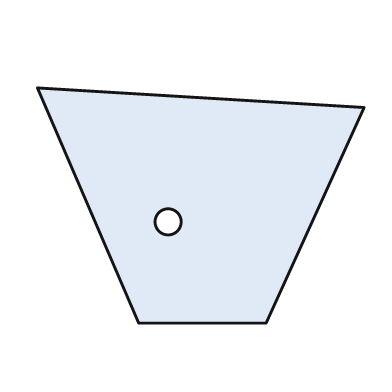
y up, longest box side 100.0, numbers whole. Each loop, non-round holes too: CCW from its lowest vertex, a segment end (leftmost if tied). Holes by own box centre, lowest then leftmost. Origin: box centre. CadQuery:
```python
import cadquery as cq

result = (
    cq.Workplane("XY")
    .moveTo(-19.0, -36.0)
    .lineTo(20.0, -36.0)
    .lineTo(50.0, 30.0)
    .lineTo(-50.0, 36.0)
    .close()
    .moveTo(-10.0, -5.0)
    .circle(4.0)
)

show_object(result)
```